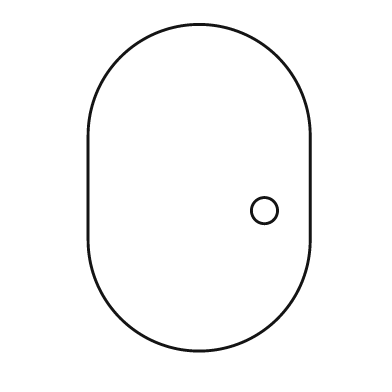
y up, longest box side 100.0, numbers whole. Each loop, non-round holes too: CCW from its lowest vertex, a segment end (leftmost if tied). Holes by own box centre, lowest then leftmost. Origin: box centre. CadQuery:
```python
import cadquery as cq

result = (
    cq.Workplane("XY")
    .moveTo(-34.0, -16.0)
    .threePointArc((0.0, -50.0), (34.0, -16.0))
    .lineTo(34.0, 16.0)
    .threePointArc((0.0, 50.0), (-34.0, 16.0))
    .close()
    .moveTo(20.0, -7.0)
    .circle(4.0)
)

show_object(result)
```